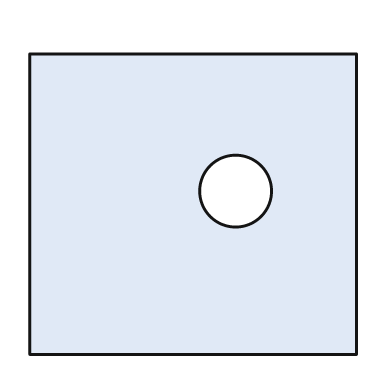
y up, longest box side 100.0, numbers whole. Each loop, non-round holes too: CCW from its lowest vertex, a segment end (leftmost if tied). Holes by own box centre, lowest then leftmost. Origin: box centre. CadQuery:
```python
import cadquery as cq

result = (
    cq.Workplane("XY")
    .moveTo(-50.0, -46.0)
    .lineTo(50.0, -46.0)
    .lineTo(50.0, 46.0)
    .lineTo(-50.0, 46.0)
    .close()
    .moveTo(13.0, 4.0)
    .circle(11.0)
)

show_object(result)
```